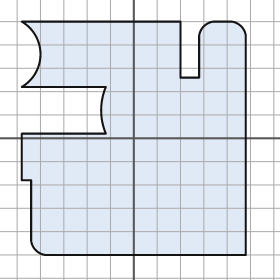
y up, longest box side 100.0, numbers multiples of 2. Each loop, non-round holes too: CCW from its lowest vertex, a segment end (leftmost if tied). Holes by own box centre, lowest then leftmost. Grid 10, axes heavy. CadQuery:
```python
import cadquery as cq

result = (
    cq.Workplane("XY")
    .moveTo(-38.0, -50.0)
    .lineTo(48.0, -50.0)
    .lineTo(48.0, 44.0)
    .threePointArc((46.0, 48.0), (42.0, 50.0))
    .lineTo(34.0, 50.0)
    .threePointArc((30.0, 48.0), (28.0, 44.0))
    .lineTo(28.0, 26.0)
    .lineTo(20.0, 26.0)
    .lineTo(20.0, 50.0)
    .lineTo(-48.0, 50.0)
    .threePointArc((-40.0, 36.0), (-48.0, 22.0))
    .lineTo(-12.0, 22.0)
    .threePointArc((-14.0, 12.0), (-12.0, 2.0))
    .lineTo(-48.0, 2.0)
    .lineTo(-48.0, -18.0)
    .lineTo(-44.0, -18.0)
    .lineTo(-44.0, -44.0)
    .threePointArc((-42.0, -48.0), (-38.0, -50.0))
    .close()
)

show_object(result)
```